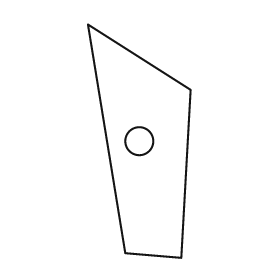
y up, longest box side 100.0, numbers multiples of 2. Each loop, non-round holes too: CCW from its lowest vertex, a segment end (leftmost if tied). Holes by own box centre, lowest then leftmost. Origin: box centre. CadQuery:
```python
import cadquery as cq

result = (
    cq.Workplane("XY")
    .moveTo(18.0, -50.0)
    .lineTo(22.0, 22.0)
    .lineTo(-22.0, 50.0)
    .lineTo(-6.0, -48.0)
    .close()
    .moveTo(0.0, 0.0)
    .circle(6.0)
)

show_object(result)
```